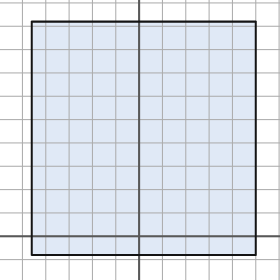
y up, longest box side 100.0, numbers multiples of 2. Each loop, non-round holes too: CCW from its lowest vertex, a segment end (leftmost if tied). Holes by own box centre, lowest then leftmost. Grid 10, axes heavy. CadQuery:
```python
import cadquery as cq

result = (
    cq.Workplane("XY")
    .moveTo(-46.0, -8.0)
    .lineTo(50.0, -8.0)
    .lineTo(50.0, 92.0)
    .lineTo(-46.0, 92.0)
    .close()
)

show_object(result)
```